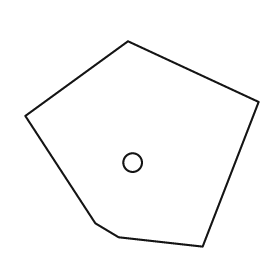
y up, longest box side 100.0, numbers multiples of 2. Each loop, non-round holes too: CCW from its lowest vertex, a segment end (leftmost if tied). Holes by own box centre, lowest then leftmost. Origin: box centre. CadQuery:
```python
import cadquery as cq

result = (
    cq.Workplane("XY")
    .moveTo(26.0, -44.0)
    .lineTo(50.0, 18.0)
    .lineTo(-6.0, 44.0)
    .lineTo(-50.0, 12.0)
    .lineTo(-20.0, -34.0)
    .lineTo(-10.0, -40.0)
    .close()
    .moveTo(-4.0, -8.0)
    .circle(4.0)
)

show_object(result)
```